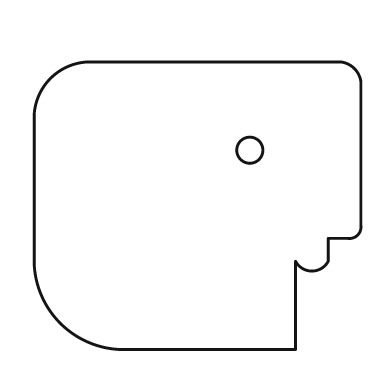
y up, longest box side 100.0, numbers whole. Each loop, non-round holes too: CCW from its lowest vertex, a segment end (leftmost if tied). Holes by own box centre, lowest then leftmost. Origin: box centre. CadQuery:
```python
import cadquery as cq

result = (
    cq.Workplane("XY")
    .moveTo(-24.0, -44.0)
    .lineTo(30.0, -44.0)
    .lineTo(30.0, -17.0)
    .threePointArc((35.0, -20.0), (40.0, -17.0))
    .lineTo(40.0, -10.0)
    .lineTo(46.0, -10.0)
    .threePointArc((49.0, -9.0), (50.0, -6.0))
    .lineTo(50.0, 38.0)
    .threePointArc((48.0, 42.0), (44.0, 44.0))
    .lineTo(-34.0, 44.0)
    .threePointArc((-45.0, 39.0), (-50.0, 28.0))
    .lineTo(-50.0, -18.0)
    .threePointArc((-42.0, -36.0), (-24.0, -44.0))
    .close()
    .moveTo(16.0, 17.0)
    .circle(4.0)
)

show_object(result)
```